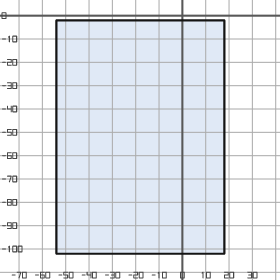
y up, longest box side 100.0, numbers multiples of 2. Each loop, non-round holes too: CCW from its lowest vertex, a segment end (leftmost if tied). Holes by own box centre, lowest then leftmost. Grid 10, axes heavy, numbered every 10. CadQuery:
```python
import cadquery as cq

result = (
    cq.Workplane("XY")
    .moveTo(-54.0, -102.0)
    .lineTo(18.0, -102.0)
    .lineTo(18.0, -2.0)
    .lineTo(-54.0, -2.0)
    .close()
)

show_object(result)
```